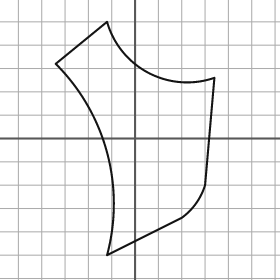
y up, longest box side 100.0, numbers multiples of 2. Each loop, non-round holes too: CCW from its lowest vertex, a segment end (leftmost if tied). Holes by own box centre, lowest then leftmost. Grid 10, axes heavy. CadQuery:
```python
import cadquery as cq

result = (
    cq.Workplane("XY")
    .moveTo(-12.0, -50.0)
    .lineTo(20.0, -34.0)
    .threePointArc((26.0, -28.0), (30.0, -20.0))
    .lineTo(34.0, 26.0)
    .threePointArc((6.0, 28.0), (-12.0, 50.0))
    .lineTo(-34.0, 32.0)
    .threePointArc((-12.0, -6.0), (-12.0, -50.0))
    .close()
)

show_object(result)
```